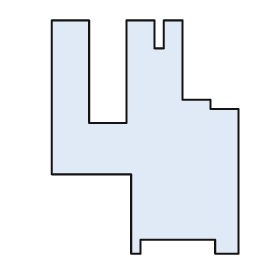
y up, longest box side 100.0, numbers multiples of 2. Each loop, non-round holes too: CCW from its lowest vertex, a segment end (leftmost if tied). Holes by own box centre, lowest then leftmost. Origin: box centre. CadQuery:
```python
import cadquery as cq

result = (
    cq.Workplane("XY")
    .moveTo(-6.0, -50.0)
    .lineTo(-2.0, -50.0)
    .lineTo(-2.0, -44.0)
    .lineTo(30.0, -44.0)
    .lineTo(30.0, -50.0)
    .lineTo(40.0, -50.0)
    .lineTo(40.0, 12.0)
    .lineTo(28.0, 12.0)
    .lineTo(28.0, 16.0)
    .lineTo(16.0, 16.0)
    .lineTo(16.0, 50.0)
    .lineTo(8.0, 50.0)
    .lineTo(8.0, 38.0)
    .lineTo(4.0, 38.0)
    .lineTo(4.0, 50.0)
    .lineTo(-8.0, 50.0)
    .lineTo(-8.0, 6.0)
    .lineTo(-24.0, 6.0)
    .lineTo(-24.0, 50.0)
    .lineTo(-40.0, 50.0)
    .lineTo(-40.0, -16.0)
    .lineTo(-6.0, -16.0)
    .close()
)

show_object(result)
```